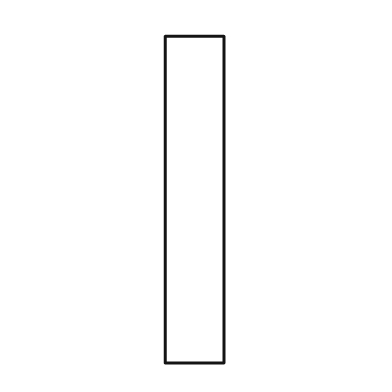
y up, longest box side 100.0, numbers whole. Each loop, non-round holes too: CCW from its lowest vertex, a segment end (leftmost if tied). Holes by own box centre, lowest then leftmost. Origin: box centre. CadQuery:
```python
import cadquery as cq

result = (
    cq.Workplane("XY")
    .moveTo(-9.0, -50.0)
    .lineTo(9.0, -50.0)
    .lineTo(9.0, 50.0)
    .lineTo(-9.0, 50.0)
    .close()
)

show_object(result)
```